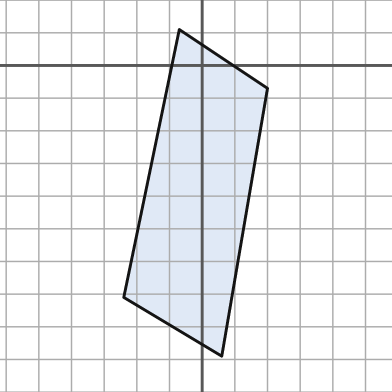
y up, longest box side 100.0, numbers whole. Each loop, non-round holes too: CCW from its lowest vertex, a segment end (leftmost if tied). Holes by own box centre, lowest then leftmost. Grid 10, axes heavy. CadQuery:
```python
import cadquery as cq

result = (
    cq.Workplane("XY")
    .moveTo(6.0, -89.0)
    .lineTo(20.0, -7.0)
    .lineTo(-7.0, 11.0)
    .lineTo(-24.0, -71.0)
    .close()
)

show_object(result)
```